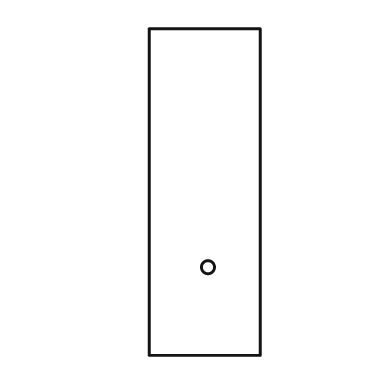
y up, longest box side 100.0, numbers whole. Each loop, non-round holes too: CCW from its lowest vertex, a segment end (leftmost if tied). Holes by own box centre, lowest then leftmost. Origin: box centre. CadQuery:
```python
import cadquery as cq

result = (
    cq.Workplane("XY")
    .moveTo(-17.0, -50.0)
    .lineTo(17.0, -50.0)
    .lineTo(17.0, 50.0)
    .lineTo(-17.0, 50.0)
    .close()
    .moveTo(1.0, -23.0)
    .circle(2.0)
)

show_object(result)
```